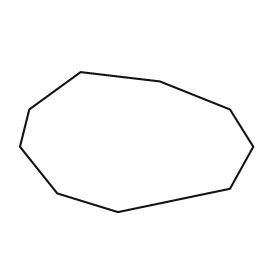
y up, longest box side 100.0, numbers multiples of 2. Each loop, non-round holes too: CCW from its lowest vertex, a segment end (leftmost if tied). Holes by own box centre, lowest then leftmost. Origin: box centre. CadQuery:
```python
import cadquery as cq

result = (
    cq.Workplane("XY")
    .moveTo(-8.0, -30.0)
    .lineTo(40.0, -20.0)
    .lineTo(50.0, -2.0)
    .lineTo(40.0, 14.0)
    .lineTo(10.0, 26.0)
    .lineTo(-24.0, 30.0)
    .lineTo(-46.0, 14.0)
    .lineTo(-50.0, -2.0)
    .lineTo(-34.0, -22.0)
    .close()
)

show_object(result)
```